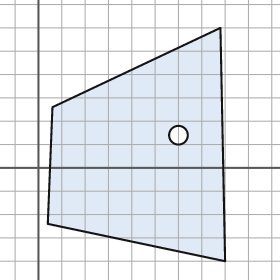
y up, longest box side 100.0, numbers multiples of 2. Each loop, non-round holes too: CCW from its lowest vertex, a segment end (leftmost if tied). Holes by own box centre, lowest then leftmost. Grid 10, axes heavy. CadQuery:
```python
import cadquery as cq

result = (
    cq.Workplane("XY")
    .moveTo(80.0, -40.0)
    .lineTo(78.0, 60.0)
    .lineTo(6.0, 26.0)
    .lineTo(4.0, -24.0)
    .close()
    .moveTo(60.0, 14.0)
    .circle(4.0)
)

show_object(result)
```